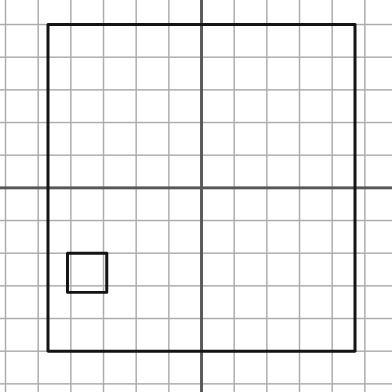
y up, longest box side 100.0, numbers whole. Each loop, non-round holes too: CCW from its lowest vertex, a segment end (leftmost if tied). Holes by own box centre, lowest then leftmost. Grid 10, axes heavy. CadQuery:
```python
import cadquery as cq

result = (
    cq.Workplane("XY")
    .moveTo(-47.0, -50.0)
    .lineTo(47.0, -50.0)
    .lineTo(47.0, 50.0)
    .lineTo(-47.0, 50.0)
    .close()
    .moveTo(-41.0, -32.0)
    .lineTo(-29.0, -32.0)
    .lineTo(-29.0, -20.0)
    .lineTo(-41.0, -20.0)
    .close()
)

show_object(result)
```